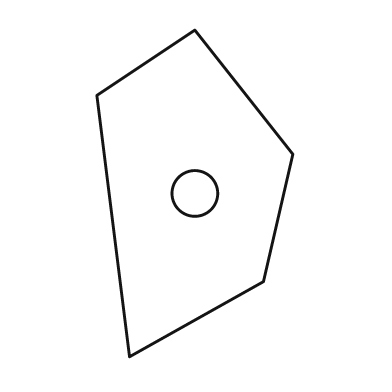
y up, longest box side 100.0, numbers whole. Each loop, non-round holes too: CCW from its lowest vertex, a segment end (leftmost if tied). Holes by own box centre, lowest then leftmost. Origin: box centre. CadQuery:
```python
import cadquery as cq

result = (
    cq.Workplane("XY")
    .moveTo(-20.0, -50.0)
    .lineTo(21.0, -27.0)
    .lineTo(30.0, 12.0)
    .lineTo(0.0, 50.0)
    .lineTo(-30.0, 30.0)
    .close()
    .moveTo(0.0, 0.0)
    .circle(7.0)
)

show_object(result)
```